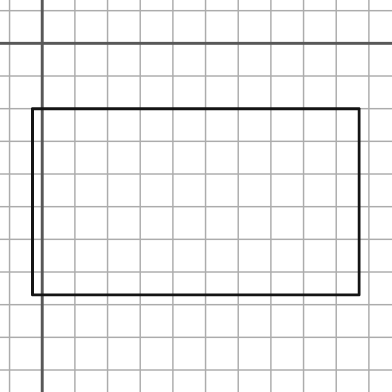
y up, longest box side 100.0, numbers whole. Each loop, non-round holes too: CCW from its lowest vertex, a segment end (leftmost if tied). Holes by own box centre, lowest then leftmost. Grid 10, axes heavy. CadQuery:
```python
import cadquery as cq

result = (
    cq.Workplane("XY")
    .moveTo(-3.0, -77.0)
    .lineTo(97.0, -77.0)
    .lineTo(97.0, -20.0)
    .lineTo(-3.0, -20.0)
    .close()
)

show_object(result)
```